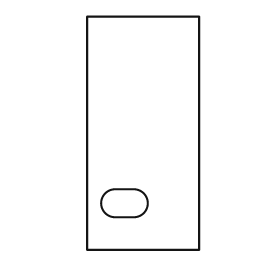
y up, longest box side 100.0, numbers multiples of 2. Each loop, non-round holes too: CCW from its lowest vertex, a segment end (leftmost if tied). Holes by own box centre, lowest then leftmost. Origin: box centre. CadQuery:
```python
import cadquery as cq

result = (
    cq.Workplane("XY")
    .moveTo(-24.0, -50.0)
    .lineTo(24.0, -50.0)
    .lineTo(24.0, 50.0)
    .lineTo(-24.0, 50.0)
    .close()
    .moveTo(-12.0, -36.0)
    .lineTo(-4.0, -36.0)
    .threePointArc((2.0, -30.0), (-4.0, -24.0))
    .lineTo(-12.0, -24.0)
    .threePointArc((-18.0, -30.0), (-12.0, -36.0))
    .close()
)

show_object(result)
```